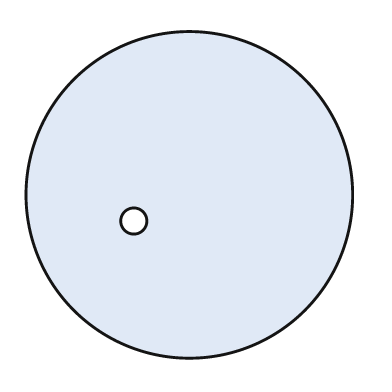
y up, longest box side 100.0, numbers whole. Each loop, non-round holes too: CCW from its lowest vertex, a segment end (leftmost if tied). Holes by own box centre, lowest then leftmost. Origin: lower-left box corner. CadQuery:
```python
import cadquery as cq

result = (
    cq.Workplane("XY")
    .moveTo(50.0, 50.0)
    .circle(50.0)
    .moveTo(33.0, 42.0)
    .circle(4.0)
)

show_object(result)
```